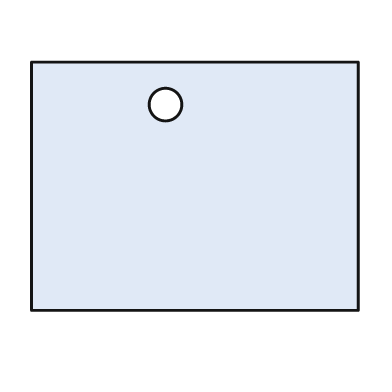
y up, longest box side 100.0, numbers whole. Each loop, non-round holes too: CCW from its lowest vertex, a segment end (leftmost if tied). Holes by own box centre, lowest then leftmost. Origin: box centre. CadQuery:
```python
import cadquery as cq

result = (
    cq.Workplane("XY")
    .moveTo(-50.0, -38.0)
    .lineTo(50.0, -38.0)
    .lineTo(50.0, 38.0)
    .lineTo(-50.0, 38.0)
    .close()
    .moveTo(-9.0, 25.0)
    .circle(5.0)
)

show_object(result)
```